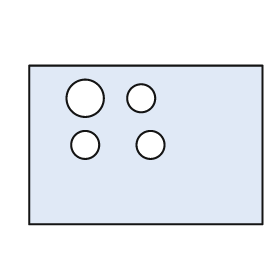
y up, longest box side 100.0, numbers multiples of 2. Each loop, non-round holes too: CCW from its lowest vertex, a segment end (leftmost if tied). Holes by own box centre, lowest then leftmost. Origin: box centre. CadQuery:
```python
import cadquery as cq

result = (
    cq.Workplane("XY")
    .moveTo(-50.0, -34.0)
    .lineTo(50.0, -34.0)
    .lineTo(50.0, 34.0)
    .lineTo(-50.0, 34.0)
    .close()
    .moveTo(-26.0, 0.0)
    .circle(6.0)
    .moveTo(2.0, 0.0)
    .circle(6.0)
    .moveTo(-26.0, 20.0)
    .circle(8.0)
    .moveTo(-2.0, 20.0)
    .circle(6.0)
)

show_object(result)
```